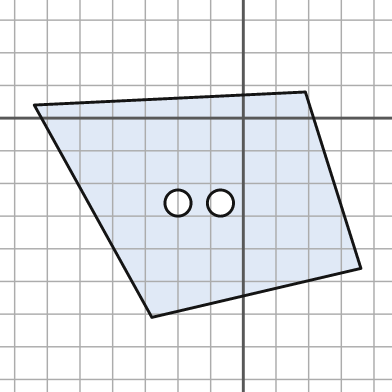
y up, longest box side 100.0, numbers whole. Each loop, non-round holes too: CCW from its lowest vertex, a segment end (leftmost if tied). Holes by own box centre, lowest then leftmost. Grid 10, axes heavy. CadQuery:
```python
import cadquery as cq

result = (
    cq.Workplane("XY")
    .moveTo(-28.0, -61.0)
    .lineTo(36.0, -46.0)
    .lineTo(19.0, 8.0)
    .lineTo(-64.0, 4.0)
    .close()
    .moveTo(-20.0, -26.0)
    .circle(4.0)
    .moveTo(-7.0, -26.0)
    .circle(4.0)
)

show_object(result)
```